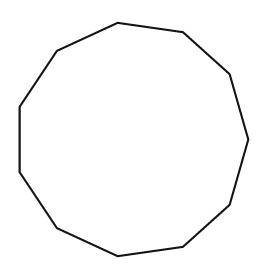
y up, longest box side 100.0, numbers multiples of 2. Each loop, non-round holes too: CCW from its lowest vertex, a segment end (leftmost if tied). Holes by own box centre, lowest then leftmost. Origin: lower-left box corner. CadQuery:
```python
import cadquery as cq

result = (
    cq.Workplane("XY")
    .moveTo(42.0, 0.0)
    .lineTo(70.0, 4.0)
    .lineTo(90.0, 22.0)
    .lineTo(98.0, 50.0)
    .lineTo(90.0, 78.0)
    .lineTo(70.0, 96.0)
    .lineTo(42.0, 100.0)
    .lineTo(16.0, 88.0)
    .lineTo(0.0, 64.0)
    .lineTo(0.0, 36.0)
    .lineTo(16.0, 12.0)
    .close()
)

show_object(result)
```